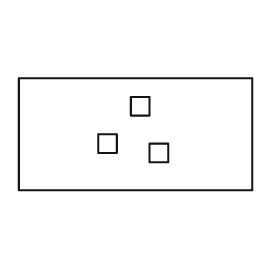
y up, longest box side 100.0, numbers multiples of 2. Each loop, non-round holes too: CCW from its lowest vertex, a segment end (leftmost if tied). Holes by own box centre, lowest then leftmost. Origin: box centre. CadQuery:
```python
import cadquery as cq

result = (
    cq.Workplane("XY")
    .moveTo(-50.0, -24.0)
    .lineTo(50.0, -24.0)
    .lineTo(50.0, 24.0)
    .lineTo(-50.0, 24.0)
    .close()
    .moveTo(6.0, -12.0)
    .lineTo(14.0, -12.0)
    .lineTo(14.0, -4.0)
    .lineTo(6.0, -4.0)
    .close()
    .moveTo(-16.0, -8.0)
    .lineTo(-8.0, -8.0)
    .lineTo(-8.0, 0.0)
    .lineTo(-16.0, 0.0)
    .close()
    .moveTo(-2.0, 8.0)
    .lineTo(6.0, 8.0)
    .lineTo(6.0, 16.0)
    .lineTo(-2.0, 16.0)
    .close()
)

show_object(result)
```